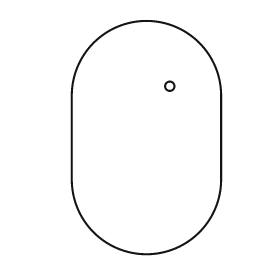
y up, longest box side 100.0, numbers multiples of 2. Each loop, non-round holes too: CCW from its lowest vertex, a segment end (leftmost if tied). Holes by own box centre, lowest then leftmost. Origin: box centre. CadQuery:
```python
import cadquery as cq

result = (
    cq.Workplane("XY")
    .moveTo(-32.0, -18.0)
    .threePointArc((0.0, -50.0), (32.0, -18.0))
    .lineTo(32.0, 18.0)
    .threePointArc((0.0, 50.0), (-32.0, 18.0))
    .close()
    .moveTo(10.0, 22.0)
    .circle(2.0)
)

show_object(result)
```